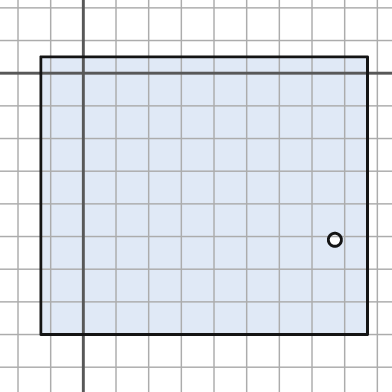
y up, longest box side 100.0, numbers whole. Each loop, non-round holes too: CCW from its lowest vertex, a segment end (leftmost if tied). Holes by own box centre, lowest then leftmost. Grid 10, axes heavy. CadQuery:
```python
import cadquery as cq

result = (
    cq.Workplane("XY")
    .moveTo(-13.0, -80.0)
    .lineTo(87.0, -80.0)
    .lineTo(87.0, 5.0)
    .lineTo(-13.0, 5.0)
    .close()
    .moveTo(77.0, -51.0)
    .circle(2.0)
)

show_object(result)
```